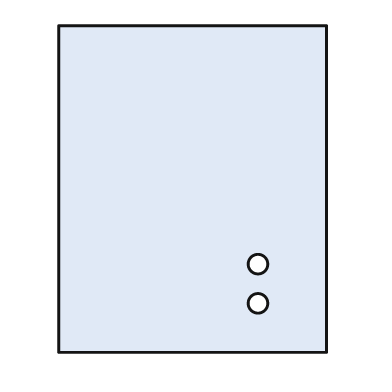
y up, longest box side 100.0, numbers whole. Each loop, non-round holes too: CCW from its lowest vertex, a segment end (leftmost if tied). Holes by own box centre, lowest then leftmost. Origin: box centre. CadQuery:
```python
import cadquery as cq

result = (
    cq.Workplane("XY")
    .moveTo(-41.0, -50.0)
    .lineTo(41.0, -50.0)
    .lineTo(41.0, 50.0)
    .lineTo(-41.0, 50.0)
    .close()
    .moveTo(20.0, -35.0)
    .circle(3.0)
    .moveTo(20.0, -23.0)
    .circle(3.0)
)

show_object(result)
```